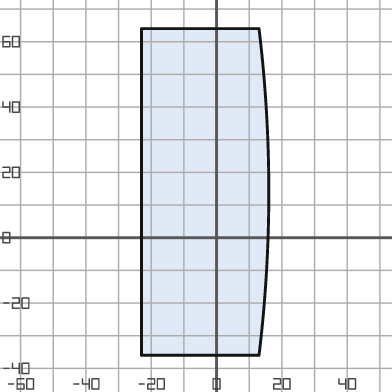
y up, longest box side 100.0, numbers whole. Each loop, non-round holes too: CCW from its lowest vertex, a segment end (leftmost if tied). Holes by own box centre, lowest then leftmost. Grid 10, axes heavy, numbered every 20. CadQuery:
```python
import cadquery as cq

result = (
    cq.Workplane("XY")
    .moveTo(-23.0, -36.0)
    .lineTo(13.0, -36.0)
    .threePointArc((16.0, 14.0), (13.0, 64.0))
    .lineTo(-23.0, 64.0)
    .close()
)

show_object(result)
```